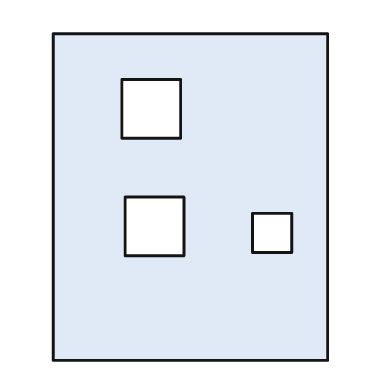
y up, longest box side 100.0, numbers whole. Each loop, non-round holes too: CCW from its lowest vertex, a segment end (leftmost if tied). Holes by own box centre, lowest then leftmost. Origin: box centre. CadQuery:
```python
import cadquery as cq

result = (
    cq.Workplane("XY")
    .moveTo(-42.0, -50.0)
    .lineTo(42.0, -50.0)
    .lineTo(42.0, 50.0)
    .lineTo(-42.0, 50.0)
    .close()
    .moveTo(19.0, -17.0)
    .lineTo(31.0, -17.0)
    .lineTo(31.0, -5.0)
    .lineTo(19.0, -5.0)
    .close()
    .moveTo(-20.0, -18.0)
    .lineTo(-2.0, -18.0)
    .lineTo(-2.0, 0.0)
    .lineTo(-20.0, 0.0)
    .close()
    .moveTo(-21.0, 18.0)
    .lineTo(-3.0, 18.0)
    .lineTo(-3.0, 36.0)
    .lineTo(-21.0, 36.0)
    .close()
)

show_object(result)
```